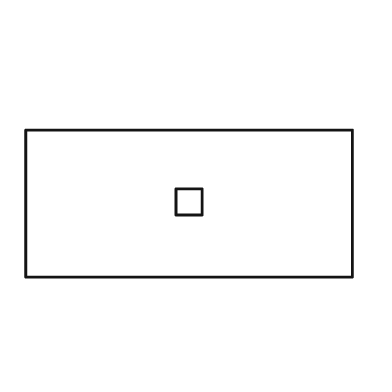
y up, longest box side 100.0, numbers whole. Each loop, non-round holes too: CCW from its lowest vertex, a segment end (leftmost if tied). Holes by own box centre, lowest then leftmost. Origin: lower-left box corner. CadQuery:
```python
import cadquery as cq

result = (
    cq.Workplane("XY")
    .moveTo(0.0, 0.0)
    .lineTo(100.0, 0.0)
    .lineTo(100.0, 45.0)
    .lineTo(0.0, 45.0)
    .close()
    .moveTo(46.0, 19.0)
    .lineTo(54.0, 19.0)
    .lineTo(54.0, 27.0)
    .lineTo(46.0, 27.0)
    .close()
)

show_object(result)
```